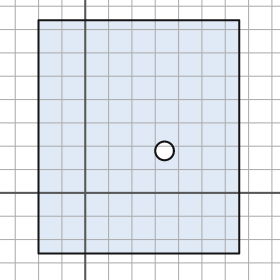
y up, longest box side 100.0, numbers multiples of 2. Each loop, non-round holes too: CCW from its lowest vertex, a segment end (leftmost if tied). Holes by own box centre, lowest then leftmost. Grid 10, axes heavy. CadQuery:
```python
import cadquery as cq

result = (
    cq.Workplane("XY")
    .moveTo(-20.0, -26.0)
    .lineTo(66.0, -26.0)
    .lineTo(66.0, 74.0)
    .lineTo(-20.0, 74.0)
    .close()
    .moveTo(34.0, 18.0)
    .circle(4.0)
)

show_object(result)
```